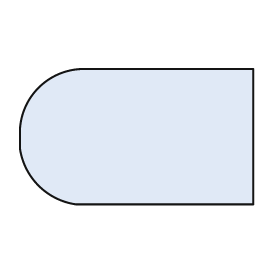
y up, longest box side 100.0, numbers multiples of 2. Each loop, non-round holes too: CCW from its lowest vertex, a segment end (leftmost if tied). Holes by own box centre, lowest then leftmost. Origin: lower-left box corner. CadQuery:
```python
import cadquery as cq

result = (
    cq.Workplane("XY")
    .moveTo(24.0, 0.0)
    .lineTo(100.0, 0.0)
    .lineTo(100.0, 58.0)
    .lineTo(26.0, 58.0)
    .threePointArc((8.0, 50.0), (0.0, 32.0))
    .lineTo(0.0, 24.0)
    .threePointArc((8.0, 8.0), (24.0, 0.0))
    .close()
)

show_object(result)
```